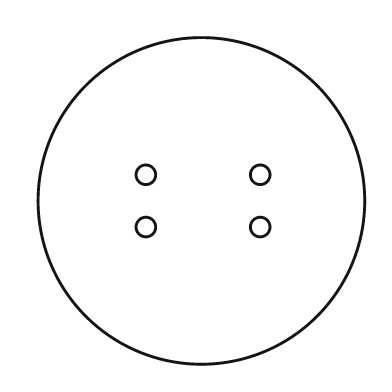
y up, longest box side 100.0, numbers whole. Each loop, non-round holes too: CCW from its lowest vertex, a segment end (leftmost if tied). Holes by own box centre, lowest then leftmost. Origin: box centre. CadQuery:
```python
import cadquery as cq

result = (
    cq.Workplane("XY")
    .moveTo(0.0, 0.0)
    .circle(50.0)
    .moveTo(-17.0, -8.0)
    .circle(3.0)
    .moveTo(18.0, -8.0)
    .circle(3.0)
    .moveTo(-17.0, 8.0)
    .circle(3.0)
    .moveTo(18.0, 8.0)
    .circle(3.0)
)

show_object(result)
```